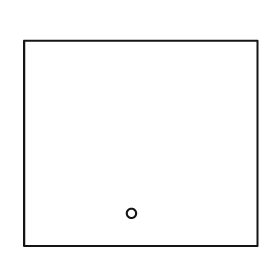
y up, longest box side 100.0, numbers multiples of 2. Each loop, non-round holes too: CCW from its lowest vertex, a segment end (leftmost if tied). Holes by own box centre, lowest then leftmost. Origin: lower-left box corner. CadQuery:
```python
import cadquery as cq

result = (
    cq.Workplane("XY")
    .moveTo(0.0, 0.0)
    .lineTo(100.0, 0.0)
    .lineTo(100.0, 88.0)
    .lineTo(0.0, 88.0)
    .close()
    .moveTo(46.0, 14.0)
    .circle(2.0)
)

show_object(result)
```